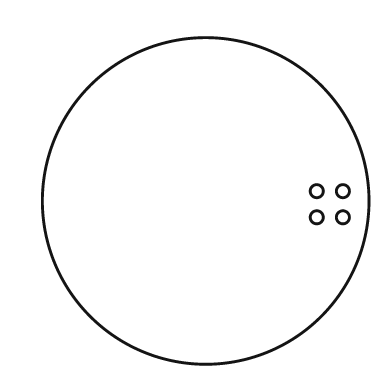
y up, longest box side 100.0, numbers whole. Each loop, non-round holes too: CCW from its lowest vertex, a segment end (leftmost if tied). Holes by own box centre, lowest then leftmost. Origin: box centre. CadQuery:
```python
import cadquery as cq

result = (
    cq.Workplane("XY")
    .moveTo(0.0, 0.0)
    .circle(50.0)
    .moveTo(34.0, -5.0)
    .circle(2.0)
    .moveTo(42.0, -5.0)
    .circle(2.0)
    .moveTo(34.0, 3.0)
    .circle(2.0)
    .moveTo(42.0, 3.0)
    .circle(2.0)
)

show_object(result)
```